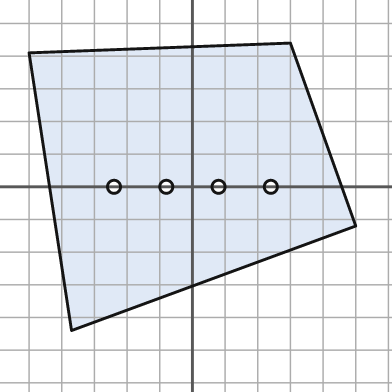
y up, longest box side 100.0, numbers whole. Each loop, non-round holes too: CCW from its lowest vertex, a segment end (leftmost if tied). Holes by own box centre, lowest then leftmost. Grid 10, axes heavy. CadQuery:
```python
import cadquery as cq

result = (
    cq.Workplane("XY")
    .moveTo(-37.0, -44.0)
    .lineTo(50.0, -12.0)
    .lineTo(30.0, 44.0)
    .lineTo(-50.0, 41.0)
    .close()
    .moveTo(-24.0, 0.0)
    .circle(2.0)
    .moveTo(-8.0, 0.0)
    .circle(2.0)
    .moveTo(8.0, 0.0)
    .circle(2.0)
    .moveTo(24.0, 0.0)
    .circle(2.0)
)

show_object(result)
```